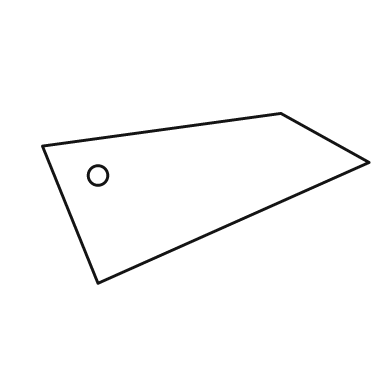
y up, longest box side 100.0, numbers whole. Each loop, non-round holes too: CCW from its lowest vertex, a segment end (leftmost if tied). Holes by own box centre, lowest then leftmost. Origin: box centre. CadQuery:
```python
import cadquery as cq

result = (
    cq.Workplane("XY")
    .moveTo(-33.0, -26.0)
    .lineTo(50.0, 11.0)
    .lineTo(23.0, 26.0)
    .lineTo(-50.0, 16.0)
    .close()
    .moveTo(-33.0, 7.0)
    .circle(3.0)
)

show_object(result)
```